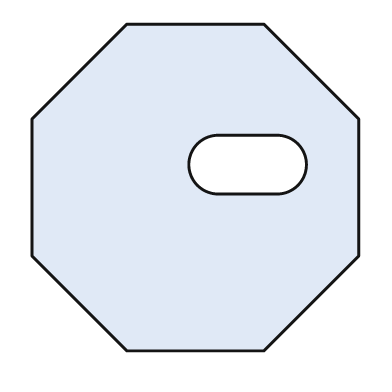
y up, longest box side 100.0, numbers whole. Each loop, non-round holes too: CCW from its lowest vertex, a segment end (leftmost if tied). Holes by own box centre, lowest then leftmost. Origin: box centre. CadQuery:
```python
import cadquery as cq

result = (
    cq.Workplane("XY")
    .moveTo(-21.0, -50.0)
    .lineTo(21.0, -50.0)
    .lineTo(50.0, -21.0)
    .lineTo(50.0, 21.0)
    .lineTo(21.0, 50.0)
    .lineTo(-21.0, 50.0)
    .lineTo(-50.0, 21.0)
    .lineTo(-50.0, -21.0)
    .close()
    .moveTo(7.0, -2.0)
    .lineTo(25.0, -2.0)
    .threePointArc((34.0, 7.0), (25.0, 16.0))
    .lineTo(7.0, 16.0)
    .threePointArc((-2.0, 7.0), (7.0, -2.0))
    .close()
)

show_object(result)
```